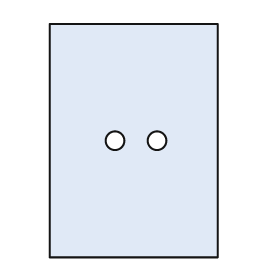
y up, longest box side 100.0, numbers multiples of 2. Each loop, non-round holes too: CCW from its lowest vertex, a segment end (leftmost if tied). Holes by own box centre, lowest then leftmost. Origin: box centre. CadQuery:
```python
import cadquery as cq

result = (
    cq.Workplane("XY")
    .moveTo(-36.0, -50.0)
    .lineTo(36.0, -50.0)
    .lineTo(36.0, 50.0)
    .lineTo(-36.0, 50.0)
    .close()
    .moveTo(-8.0, 0.0)
    .circle(4.0)
    .moveTo(10.0, 0.0)
    .circle(4.0)
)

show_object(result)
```